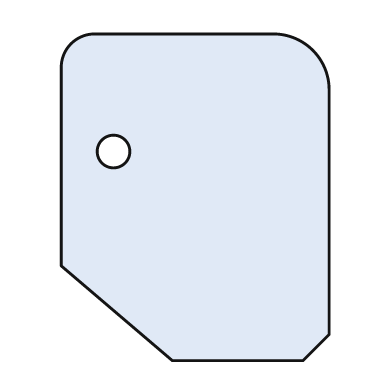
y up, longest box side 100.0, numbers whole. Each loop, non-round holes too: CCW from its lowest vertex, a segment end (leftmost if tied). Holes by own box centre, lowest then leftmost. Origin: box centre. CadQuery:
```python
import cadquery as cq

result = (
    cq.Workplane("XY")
    .moveTo(-7.0, -50.0)
    .lineTo(33.0, -50.0)
    .lineTo(41.0, -42.0)
    .lineTo(41.0, 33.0)
    .threePointArc((36.0, 45.0), (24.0, 50.0))
    .lineTo(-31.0, 50.0)
    .threePointArc((-38.0, 47.0), (-41.0, 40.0))
    .lineTo(-41.0, -21.0)
    .close()
    .moveTo(-25.0, 14.0)
    .circle(5.0)
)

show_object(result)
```